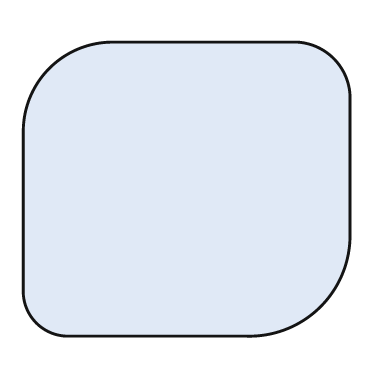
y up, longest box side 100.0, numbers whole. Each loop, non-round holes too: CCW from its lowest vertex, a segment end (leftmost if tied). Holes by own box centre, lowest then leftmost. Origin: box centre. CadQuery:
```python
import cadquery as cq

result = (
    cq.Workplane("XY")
    .moveTo(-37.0, -45.0)
    .lineTo(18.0, -45.0)
    .threePointArc((41.0, -36.0), (50.0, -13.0))
    .lineTo(50.0, 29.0)
    .threePointArc((45.0, 40.0), (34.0, 45.0))
    .lineTo(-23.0, 45.0)
    .threePointArc((-42.0, 37.0), (-50.0, 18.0))
    .lineTo(-50.0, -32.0)
    .threePointArc((-46.0, -41.0), (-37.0, -45.0))
    .close()
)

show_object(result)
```